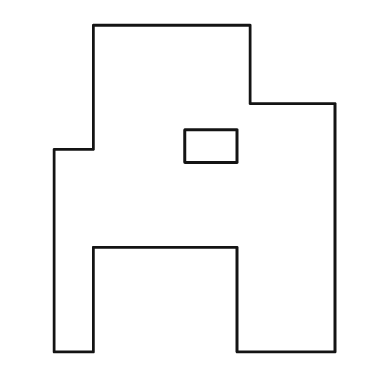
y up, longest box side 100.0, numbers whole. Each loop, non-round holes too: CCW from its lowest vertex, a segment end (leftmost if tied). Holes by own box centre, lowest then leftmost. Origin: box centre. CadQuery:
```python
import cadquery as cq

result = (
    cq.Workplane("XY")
    .moveTo(-43.0, -50.0)
    .lineTo(-31.0, -50.0)
    .lineTo(-31.0, -18.0)
    .lineTo(13.0, -18.0)
    .lineTo(13.0, -50.0)
    .lineTo(43.0, -50.0)
    .lineTo(43.0, 26.0)
    .lineTo(17.0, 26.0)
    .lineTo(17.0, 50.0)
    .lineTo(-31.0, 50.0)
    .lineTo(-31.0, 12.0)
    .lineTo(-43.0, 12.0)
    .close()
    .moveTo(-3.0, 8.0)
    .lineTo(13.0, 8.0)
    .lineTo(13.0, 18.0)
    .lineTo(-3.0, 18.0)
    .close()
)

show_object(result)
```